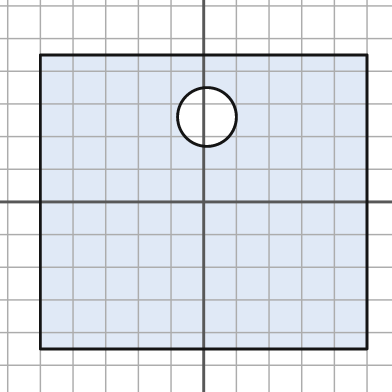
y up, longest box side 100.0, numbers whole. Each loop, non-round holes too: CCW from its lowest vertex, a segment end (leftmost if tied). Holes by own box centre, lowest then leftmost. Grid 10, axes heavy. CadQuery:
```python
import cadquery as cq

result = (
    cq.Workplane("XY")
    .moveTo(-50.0, -45.0)
    .lineTo(50.0, -45.0)
    .lineTo(50.0, 45.0)
    .lineTo(-50.0, 45.0)
    .close()
    .moveTo(1.0, 26.0)
    .circle(9.0)
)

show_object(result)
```